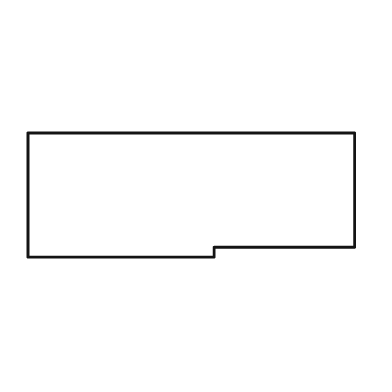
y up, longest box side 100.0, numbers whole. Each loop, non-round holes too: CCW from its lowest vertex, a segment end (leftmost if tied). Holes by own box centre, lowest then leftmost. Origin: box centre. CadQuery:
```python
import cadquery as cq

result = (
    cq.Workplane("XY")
    .moveTo(-50.0, -19.0)
    .lineTo(7.0, -19.0)
    .lineTo(7.0, -16.0)
    .lineTo(50.0, -16.0)
    .lineTo(50.0, 19.0)
    .lineTo(-50.0, 19.0)
    .close()
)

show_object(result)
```